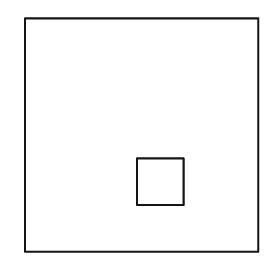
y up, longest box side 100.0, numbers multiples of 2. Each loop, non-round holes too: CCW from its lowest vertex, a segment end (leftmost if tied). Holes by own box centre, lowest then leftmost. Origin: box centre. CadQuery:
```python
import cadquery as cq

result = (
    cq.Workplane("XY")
    .moveTo(-50.0, -50.0)
    .lineTo(50.0, -50.0)
    .lineTo(50.0, 50.0)
    .lineTo(-50.0, 50.0)
    .close()
    .moveTo(-2.0, -30.0)
    .lineTo(18.0, -30.0)
    .lineTo(18.0, -10.0)
    .lineTo(-2.0, -10.0)
    .close()
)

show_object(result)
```